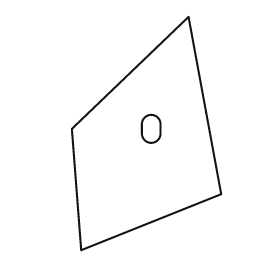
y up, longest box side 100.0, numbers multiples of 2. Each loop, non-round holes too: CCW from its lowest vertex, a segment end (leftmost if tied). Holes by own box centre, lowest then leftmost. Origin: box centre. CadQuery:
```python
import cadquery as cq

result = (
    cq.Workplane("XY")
    .moveTo(-28.0, -50.0)
    .lineTo(32.0, -26.0)
    .lineTo(18.0, 50.0)
    .lineTo(-32.0, 2.0)
    .close()
    .moveTo(-2.0, 0.0)
    .threePointArc((2.0, -4.0), (6.0, 0.0))
    .lineTo(6.0, 4.0)
    .threePointArc((2.0, 8.0), (-2.0, 4.0))
    .close()
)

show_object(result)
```